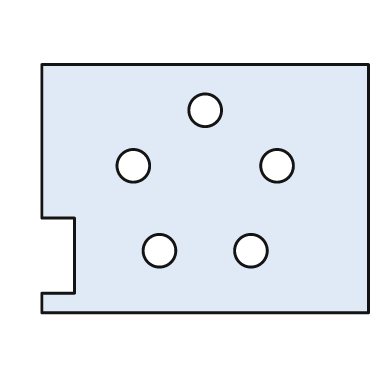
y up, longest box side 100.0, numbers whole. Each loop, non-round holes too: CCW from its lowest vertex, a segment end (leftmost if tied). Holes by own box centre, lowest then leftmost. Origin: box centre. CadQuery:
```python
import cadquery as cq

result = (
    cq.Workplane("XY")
    .moveTo(-50.0, -38.0)
    .lineTo(50.0, -38.0)
    .lineTo(50.0, 38.0)
    .lineTo(-50.0, 38.0)
    .lineTo(-50.0, -9.0)
    .lineTo(-40.0, -9.0)
    .lineTo(-40.0, -32.0)
    .lineTo(-50.0, -32.0)
    .close()
    .moveTo(-14.0, -19.0)
    .circle(5.0)
    .moveTo(14.0, -19.0)
    .circle(5.0)
    .moveTo(-22.0, 7.0)
    .circle(5.0)
    .moveTo(22.0, 7.0)
    .circle(5.0)
    .moveTo(0.0, 24.0)
    .circle(5.0)
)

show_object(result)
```